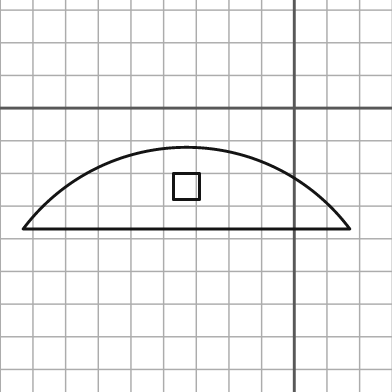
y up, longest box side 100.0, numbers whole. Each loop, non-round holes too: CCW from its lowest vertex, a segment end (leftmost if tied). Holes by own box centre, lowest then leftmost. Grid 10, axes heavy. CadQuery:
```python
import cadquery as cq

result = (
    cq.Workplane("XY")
    .moveTo(-83.0, -37.0)
    .lineTo(17.0, -37.0)
    .threePointArc((-33.0, -12.0), (-83.0, -37.0))
    .close()
    .moveTo(-37.0, -28.0)
    .lineTo(-29.0, -28.0)
    .lineTo(-29.0, -20.0)
    .lineTo(-37.0, -20.0)
    .close()
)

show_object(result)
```